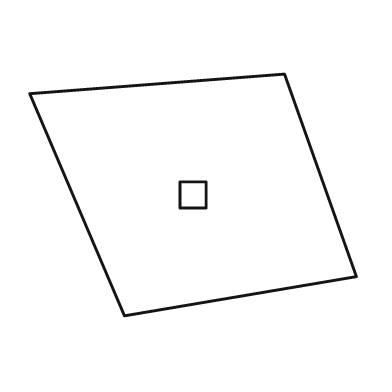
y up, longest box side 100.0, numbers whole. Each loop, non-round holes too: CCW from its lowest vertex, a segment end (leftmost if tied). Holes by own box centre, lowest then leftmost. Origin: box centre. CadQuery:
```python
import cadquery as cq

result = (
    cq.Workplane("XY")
    .moveTo(-21.0, -37.0)
    .lineTo(50.0, -25.0)
    .lineTo(28.0, 37.0)
    .lineTo(-50.0, 31.0)
    .close()
    .moveTo(-4.0, -4.0)
    .lineTo(4.0, -4.0)
    .lineTo(4.0, 4.0)
    .lineTo(-4.0, 4.0)
    .close()
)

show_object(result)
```